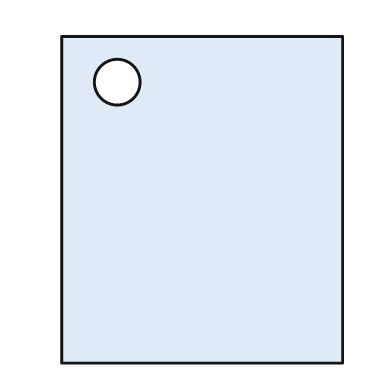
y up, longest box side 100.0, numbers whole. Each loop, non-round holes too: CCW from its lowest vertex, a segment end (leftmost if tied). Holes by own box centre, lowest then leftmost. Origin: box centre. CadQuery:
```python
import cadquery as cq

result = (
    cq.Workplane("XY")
    .moveTo(-43.0, -50.0)
    .lineTo(43.0, -50.0)
    .lineTo(43.0, 50.0)
    .lineTo(-43.0, 50.0)
    .close()
    .moveTo(-26.0, 36.0)
    .circle(7.0)
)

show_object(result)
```